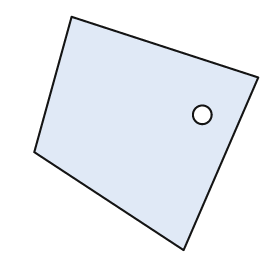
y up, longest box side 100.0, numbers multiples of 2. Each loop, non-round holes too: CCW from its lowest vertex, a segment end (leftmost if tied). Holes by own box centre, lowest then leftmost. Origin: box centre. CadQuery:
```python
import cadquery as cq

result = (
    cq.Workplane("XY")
    .moveTo(16.0, -50.0)
    .lineTo(48.0, 24.0)
    .lineTo(-32.0, 50.0)
    .lineTo(-48.0, -8.0)
    .close()
    .moveTo(24.0, 8.0)
    .circle(4.0)
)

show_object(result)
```